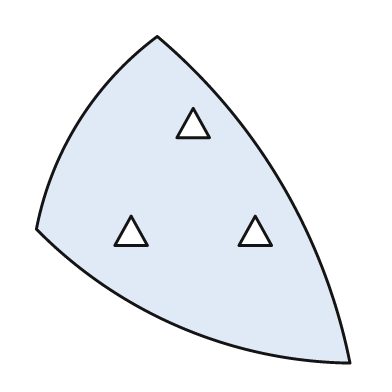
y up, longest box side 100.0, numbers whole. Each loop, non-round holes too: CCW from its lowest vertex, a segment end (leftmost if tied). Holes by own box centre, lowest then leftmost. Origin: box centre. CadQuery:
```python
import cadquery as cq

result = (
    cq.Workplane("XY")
    .moveTo(48.0, -50.0)
    .threePointArc((27.0, 5.0), (-11.0, 50.0))
    .threePointArc((-35.0, 24.0), (-48.0, -9.0))
    .threePointArc((-4.0, -39.0), (48.0, -50.0))
    .close()
    .moveTo(-24.0, -14.0)
    .lineTo(-14.0, -14.0)
    .lineTo(-19.0, -5.0)
    .close()
    .moveTo(14.0, -14.0)
    .lineTo(24.0, -14.0)
    .lineTo(19.0, -5.0)
    .close()
    .moveTo(-5.0, 19.0)
    .lineTo(5.0, 19.0)
    .lineTo(0.0, 28.0)
    .close()
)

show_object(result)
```